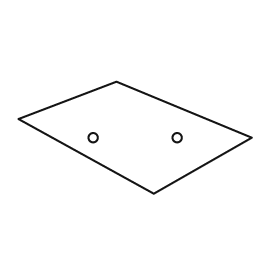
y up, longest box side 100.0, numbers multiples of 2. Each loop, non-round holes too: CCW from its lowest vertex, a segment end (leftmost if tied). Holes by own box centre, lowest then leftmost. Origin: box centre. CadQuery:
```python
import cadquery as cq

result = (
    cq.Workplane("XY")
    .moveTo(8.0, -24.0)
    .lineTo(50.0, 0.0)
    .lineTo(-8.0, 24.0)
    .lineTo(-50.0, 8.0)
    .close()
    .moveTo(-18.0, 0.0)
    .circle(2.0)
    .moveTo(18.0, 0.0)
    .circle(2.0)
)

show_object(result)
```